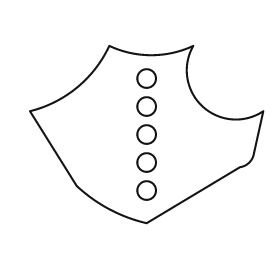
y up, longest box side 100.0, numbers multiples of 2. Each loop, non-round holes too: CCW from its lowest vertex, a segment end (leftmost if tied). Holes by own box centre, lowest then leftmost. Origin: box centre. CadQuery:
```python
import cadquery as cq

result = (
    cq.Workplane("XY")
    .moveTo(0.0, -38.0)
    .lineTo(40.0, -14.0)
    .threePointArc((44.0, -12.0), (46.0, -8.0))
    .lineTo(50.0, 10.0)
    .threePointArc((24.0, 12.0), (20.0, 38.0))
    .threePointArc((2.0, 34.0), (-16.0, 38.0))
    .threePointArc((-30.0, 20.0), (-50.0, 10.0))
    .lineTo(-30.0, -22.0)
    .threePointArc((-16.0, -32.0), (0.0, -38.0))
    .close()
    .moveTo(0.0, -24.0)
    .circle(4.0)
    .moveTo(0.0, -12.0)
    .circle(4.0)
    .moveTo(0.0, 0.0)
    .circle(4.0)
    .moveTo(0.0, 12.0)
    .circle(4.0)
    .moveTo(0.0, 24.0)
    .circle(4.0)
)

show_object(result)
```